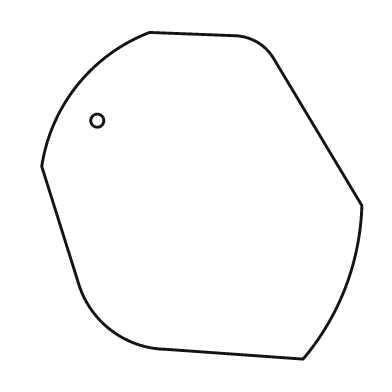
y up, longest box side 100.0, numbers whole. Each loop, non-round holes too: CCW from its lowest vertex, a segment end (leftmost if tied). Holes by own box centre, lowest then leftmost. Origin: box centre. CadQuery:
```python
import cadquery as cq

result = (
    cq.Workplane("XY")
    .moveTo(31.0, -50.0)
    .threePointArc((44.0, -28.0), (49.0, -3.0))
    .lineTo(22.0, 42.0)
    .threePointArc((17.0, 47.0), (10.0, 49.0))
    .lineTo(-16.0, 50.0)
    .threePointArc((-38.0, 34.0), (-49.0, 9.0))
    .lineTo(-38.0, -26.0)
    .threePointArc((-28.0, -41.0), (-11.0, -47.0))
    .close()
    .moveTo(-32.0, 23.0)
    .circle(2.0)
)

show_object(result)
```